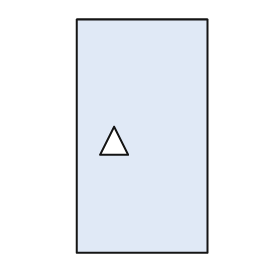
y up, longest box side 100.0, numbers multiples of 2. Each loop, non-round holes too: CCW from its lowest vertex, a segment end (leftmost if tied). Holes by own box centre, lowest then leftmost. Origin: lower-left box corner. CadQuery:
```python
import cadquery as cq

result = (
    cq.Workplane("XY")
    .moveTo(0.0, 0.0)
    .lineTo(56.0, 0.0)
    .lineTo(56.0, 100.0)
    .lineTo(0.0, 100.0)
    .close()
    .moveTo(10.0, 42.0)
    .lineTo(22.0, 42.0)
    .lineTo(16.0, 54.0)
    .close()
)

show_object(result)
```